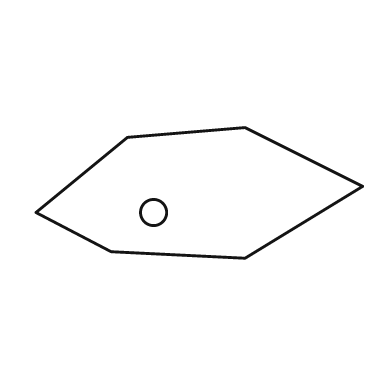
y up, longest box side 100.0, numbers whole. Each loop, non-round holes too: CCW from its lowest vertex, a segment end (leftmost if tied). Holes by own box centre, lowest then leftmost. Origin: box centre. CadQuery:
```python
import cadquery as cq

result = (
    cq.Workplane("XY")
    .moveTo(14.0, -20.0)
    .lineTo(50.0, 2.0)
    .lineTo(14.0, 20.0)
    .lineTo(-22.0, 17.0)
    .lineTo(-50.0, -6.0)
    .lineTo(-27.0, -18.0)
    .close()
    .moveTo(-14.0, -6.0)
    .circle(4.0)
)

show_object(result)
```